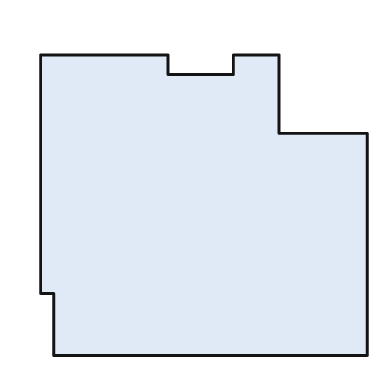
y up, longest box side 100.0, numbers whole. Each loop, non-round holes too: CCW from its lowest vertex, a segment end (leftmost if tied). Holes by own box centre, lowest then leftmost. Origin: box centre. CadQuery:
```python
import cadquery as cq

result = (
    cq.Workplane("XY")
    .moveTo(-46.0, -46.0)
    .lineTo(50.0, -46.0)
    .lineTo(50.0, 22.0)
    .lineTo(23.0, 22.0)
    .lineTo(23.0, 46.0)
    .lineTo(9.0, 46.0)
    .lineTo(9.0, 40.0)
    .lineTo(-11.0, 40.0)
    .lineTo(-11.0, 46.0)
    .lineTo(-50.0, 46.0)
    .lineTo(-50.0, -27.0)
    .lineTo(-46.0, -27.0)
    .close()
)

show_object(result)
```